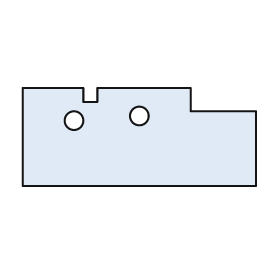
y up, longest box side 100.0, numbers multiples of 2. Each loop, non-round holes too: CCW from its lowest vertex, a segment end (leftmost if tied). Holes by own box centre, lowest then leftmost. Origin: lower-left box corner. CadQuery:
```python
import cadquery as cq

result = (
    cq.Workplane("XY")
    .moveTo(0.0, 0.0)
    .lineTo(100.0, 0.0)
    .lineTo(100.0, 32.0)
    .lineTo(72.0, 32.0)
    .lineTo(72.0, 42.0)
    .lineTo(32.0, 42.0)
    .lineTo(32.0, 36.0)
    .lineTo(26.0, 36.0)
    .lineTo(26.0, 42.0)
    .lineTo(0.0, 42.0)
    .close()
    .moveTo(22.0, 28.0)
    .circle(4.0)
    .moveTo(50.0, 30.0)
    .circle(4.0)
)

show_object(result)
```